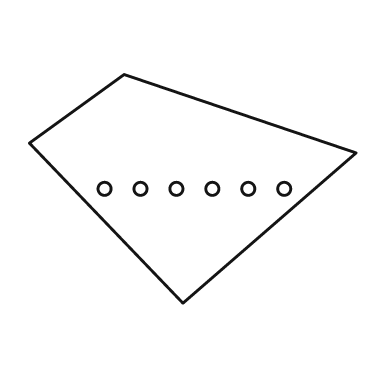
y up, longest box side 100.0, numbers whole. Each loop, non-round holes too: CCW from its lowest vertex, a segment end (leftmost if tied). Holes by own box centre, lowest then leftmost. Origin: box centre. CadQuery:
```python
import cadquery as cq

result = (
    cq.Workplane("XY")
    .moveTo(-3.0, -35.0)
    .lineTo(50.0, 11.0)
    .lineTo(-21.0, 35.0)
    .lineTo(-50.0, 14.0)
    .close()
    .moveTo(-27.0, 0.0)
    .circle(2.0)
    .moveTo(-16.0, 0.0)
    .circle(2.0)
    .moveTo(-5.0, 0.0)
    .circle(2.0)
    .moveTo(6.0, 0.0)
    .circle(2.0)
    .moveTo(17.0, 0.0)
    .circle(2.0)
    .moveTo(28.0, 0.0)
    .circle(2.0)
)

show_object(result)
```